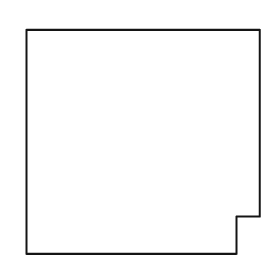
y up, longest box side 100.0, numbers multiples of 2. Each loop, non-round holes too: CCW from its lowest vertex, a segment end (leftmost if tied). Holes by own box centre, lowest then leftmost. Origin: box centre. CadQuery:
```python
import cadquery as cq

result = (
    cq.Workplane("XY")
    .moveTo(-50.0, -48.0)
    .lineTo(40.0, -48.0)
    .lineTo(40.0, -32.0)
    .lineTo(50.0, -32.0)
    .lineTo(50.0, 48.0)
    .lineTo(-50.0, 48.0)
    .close()
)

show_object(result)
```